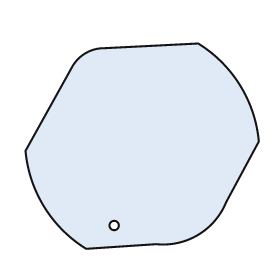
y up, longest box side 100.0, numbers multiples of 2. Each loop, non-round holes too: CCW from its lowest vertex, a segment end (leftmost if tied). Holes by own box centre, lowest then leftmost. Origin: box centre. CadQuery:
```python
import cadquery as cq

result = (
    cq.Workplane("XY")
    .moveTo(-24.0, -44.0)
    .lineTo(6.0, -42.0)
    .threePointArc((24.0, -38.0), (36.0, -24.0))
    .lineTo(50.0, 2.0)
    .threePointArc((42.0, 26.0), (24.0, 44.0))
    .lineTo(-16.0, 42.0)
    .threePointArc((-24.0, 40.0), (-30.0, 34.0))
    .lineTo(-50.0, -2.0)
    .threePointArc((-42.0, -26.0), (-24.0, -44.0))
    .close()
    .moveTo(-12.0, -34.0)
    .circle(2.0)
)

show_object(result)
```